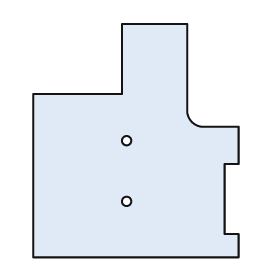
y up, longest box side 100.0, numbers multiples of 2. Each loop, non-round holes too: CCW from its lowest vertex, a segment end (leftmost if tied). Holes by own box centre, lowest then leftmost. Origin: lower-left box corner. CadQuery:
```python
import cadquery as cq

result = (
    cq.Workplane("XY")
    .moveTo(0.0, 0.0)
    .lineTo(88.0, 0.0)
    .lineTo(88.0, 10.0)
    .lineTo(82.0, 10.0)
    .lineTo(82.0, 40.0)
    .lineTo(88.0, 40.0)
    .lineTo(88.0, 56.0)
    .lineTo(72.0, 56.0)
    .threePointArc((68.0, 58.0), (66.0, 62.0))
    .lineTo(66.0, 100.0)
    .lineTo(38.0, 100.0)
    .lineTo(38.0, 70.0)
    .lineTo(0.0, 70.0)
    .close()
    .moveTo(40.0, 24.0)
    .circle(2.0)
    .moveTo(40.0, 50.0)
    .circle(2.0)
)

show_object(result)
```